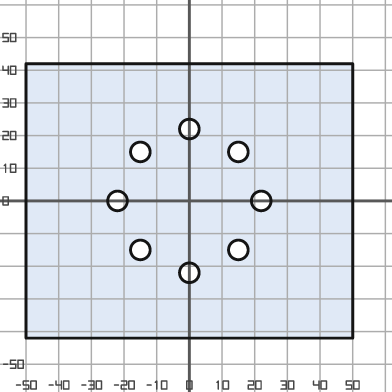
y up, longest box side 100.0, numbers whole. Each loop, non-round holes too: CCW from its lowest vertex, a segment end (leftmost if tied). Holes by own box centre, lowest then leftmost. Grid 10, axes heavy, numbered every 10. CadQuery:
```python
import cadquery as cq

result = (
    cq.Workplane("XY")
    .moveTo(-50.0, -42.0)
    .lineTo(50.0, -42.0)
    .lineTo(50.0, 42.0)
    .lineTo(-50.0, 42.0)
    .close()
    .moveTo(0.0, -22.0)
    .circle(3.0)
    .moveTo(-15.0, -15.0)
    .circle(3.0)
    .moveTo(15.0, -15.0)
    .circle(3.0)
    .moveTo(-22.0, 0.0)
    .circle(3.0)
    .moveTo(22.0, 0.0)
    .circle(3.0)
    .moveTo(-15.0, 15.0)
    .circle(3.0)
    .moveTo(15.0, 15.0)
    .circle(3.0)
    .moveTo(0.0, 22.0)
    .circle(3.0)
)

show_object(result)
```